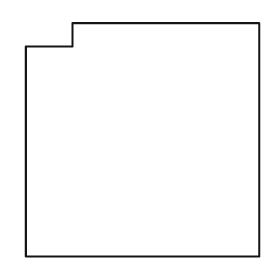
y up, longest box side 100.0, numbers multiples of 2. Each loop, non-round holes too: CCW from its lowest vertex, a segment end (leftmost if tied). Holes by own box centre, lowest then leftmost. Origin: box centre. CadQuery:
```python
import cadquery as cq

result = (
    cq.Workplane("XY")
    .moveTo(-50.0, -50.0)
    .lineTo(50.0, -50.0)
    .lineTo(50.0, 50.0)
    .lineTo(-30.0, 50.0)
    .lineTo(-30.0, 40.0)
    .lineTo(-50.0, 40.0)
    .close()
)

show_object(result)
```